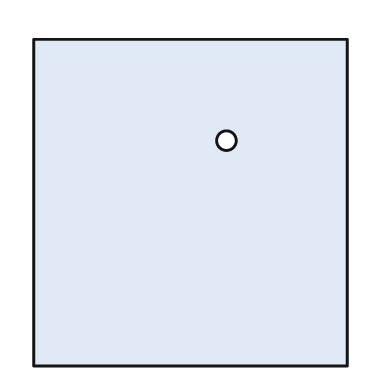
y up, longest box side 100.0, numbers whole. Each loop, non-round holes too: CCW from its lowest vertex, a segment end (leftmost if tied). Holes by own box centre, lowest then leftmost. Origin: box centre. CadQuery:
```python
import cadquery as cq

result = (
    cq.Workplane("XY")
    .moveTo(-48.0, -50.0)
    .lineTo(48.0, -50.0)
    .lineTo(48.0, 50.0)
    .lineTo(-48.0, 50.0)
    .close()
    .moveTo(11.0, 19.0)
    .circle(3.0)
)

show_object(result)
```